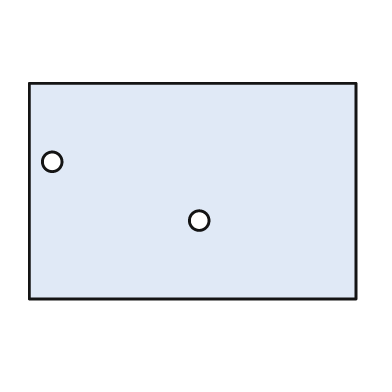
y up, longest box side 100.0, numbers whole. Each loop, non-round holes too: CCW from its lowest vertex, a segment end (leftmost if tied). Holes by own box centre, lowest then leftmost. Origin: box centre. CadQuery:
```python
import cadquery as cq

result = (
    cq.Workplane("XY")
    .moveTo(-50.0, -33.0)
    .lineTo(50.0, -33.0)
    .lineTo(50.0, 33.0)
    .lineTo(-50.0, 33.0)
    .close()
    .moveTo(2.0, -9.0)
    .circle(3.0)
    .moveTo(-43.0, 9.0)
    .circle(3.0)
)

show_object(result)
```